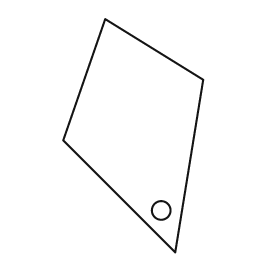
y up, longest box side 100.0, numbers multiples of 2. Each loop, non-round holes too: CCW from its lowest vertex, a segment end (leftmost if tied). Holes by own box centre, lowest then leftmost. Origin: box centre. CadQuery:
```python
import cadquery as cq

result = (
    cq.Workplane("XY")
    .moveTo(18.0, -50.0)
    .lineTo(30.0, 24.0)
    .lineTo(-12.0, 50.0)
    .lineTo(-30.0, -2.0)
    .close()
    .moveTo(12.0, -32.0)
    .circle(4.0)
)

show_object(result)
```